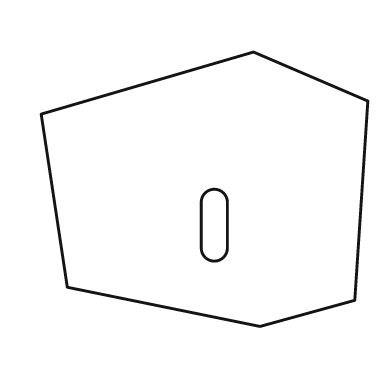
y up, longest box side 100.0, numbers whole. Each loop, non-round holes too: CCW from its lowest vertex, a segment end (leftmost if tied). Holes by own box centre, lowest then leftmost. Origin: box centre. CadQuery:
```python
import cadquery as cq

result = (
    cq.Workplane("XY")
    .moveTo(17.0, -42.0)
    .lineTo(46.0, -34.0)
    .lineTo(50.0, 27.0)
    .lineTo(15.0, 42.0)
    .lineTo(-50.0, 23.0)
    .lineTo(-42.0, -30.0)
    .close()
    .moveTo(-1.0, -18.0)
    .threePointArc((3.0, -22.0), (7.0, -18.0))
    .lineTo(7.0, -4.0)
    .threePointArc((3.0, 0.0), (-1.0, -4.0))
    .close()
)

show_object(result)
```